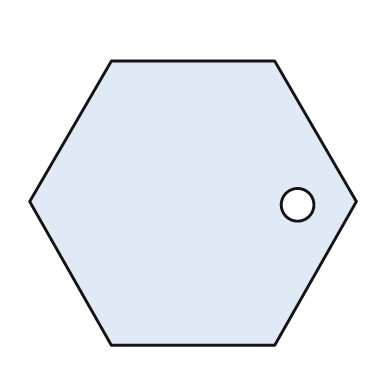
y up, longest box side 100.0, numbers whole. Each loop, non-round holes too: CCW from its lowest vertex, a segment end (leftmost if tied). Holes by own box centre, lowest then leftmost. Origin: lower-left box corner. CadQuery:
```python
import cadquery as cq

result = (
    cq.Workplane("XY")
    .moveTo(25.0, 0.0)
    .lineTo(75.0, 0.0)
    .lineTo(100.0, 44.0)
    .lineTo(75.0, 87.0)
    .lineTo(25.0, 87.0)
    .lineTo(0.0, 44.0)
    .close()
    .moveTo(82.0, 43.0)
    .circle(5.0)
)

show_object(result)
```